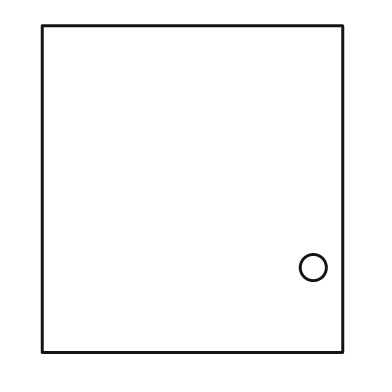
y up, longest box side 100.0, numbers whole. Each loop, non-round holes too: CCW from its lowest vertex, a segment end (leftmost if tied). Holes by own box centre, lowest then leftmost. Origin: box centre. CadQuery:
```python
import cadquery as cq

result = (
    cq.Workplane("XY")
    .moveTo(-46.0, -50.0)
    .lineTo(46.0, -50.0)
    .lineTo(46.0, 50.0)
    .lineTo(-46.0, 50.0)
    .close()
    .moveTo(37.0, -24.0)
    .circle(4.0)
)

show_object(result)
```